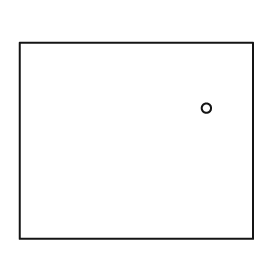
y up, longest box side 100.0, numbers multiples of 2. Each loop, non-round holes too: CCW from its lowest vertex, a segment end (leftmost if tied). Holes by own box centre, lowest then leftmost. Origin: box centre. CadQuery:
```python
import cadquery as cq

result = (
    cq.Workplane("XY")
    .moveTo(-50.0, -42.0)
    .lineTo(50.0, -42.0)
    .lineTo(50.0, 42.0)
    .lineTo(-50.0, 42.0)
    .close()
    .moveTo(30.0, 14.0)
    .circle(2.0)
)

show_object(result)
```